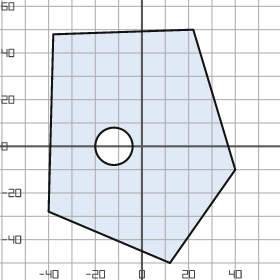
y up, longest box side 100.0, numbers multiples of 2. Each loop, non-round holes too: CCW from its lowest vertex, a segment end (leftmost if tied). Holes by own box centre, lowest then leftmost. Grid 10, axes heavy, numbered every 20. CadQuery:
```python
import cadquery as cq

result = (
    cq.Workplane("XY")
    .moveTo(12.0, -50.0)
    .lineTo(40.0, -10.0)
    .lineTo(22.0, 50.0)
    .lineTo(-38.0, 48.0)
    .lineTo(-40.0, -28.0)
    .close()
    .moveTo(-12.0, 0.0)
    .circle(8.0)
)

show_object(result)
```